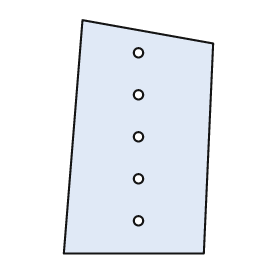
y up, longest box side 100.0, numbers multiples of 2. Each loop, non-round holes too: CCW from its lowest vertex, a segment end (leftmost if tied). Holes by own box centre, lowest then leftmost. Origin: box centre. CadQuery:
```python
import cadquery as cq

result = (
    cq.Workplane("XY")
    .moveTo(-32.0, -50.0)
    .lineTo(28.0, -50.0)
    .lineTo(32.0, 40.0)
    .lineTo(-24.0, 50.0)
    .close()
    .moveTo(0.0, -36.0)
    .circle(2.0)
    .moveTo(0.0, -18.0)
    .circle(2.0)
    .moveTo(0.0, 0.0)
    .circle(2.0)
    .moveTo(0.0, 18.0)
    .circle(2.0)
    .moveTo(0.0, 36.0)
    .circle(2.0)
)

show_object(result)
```